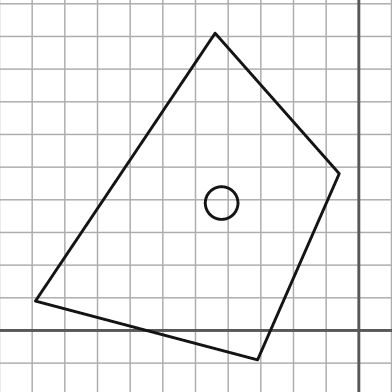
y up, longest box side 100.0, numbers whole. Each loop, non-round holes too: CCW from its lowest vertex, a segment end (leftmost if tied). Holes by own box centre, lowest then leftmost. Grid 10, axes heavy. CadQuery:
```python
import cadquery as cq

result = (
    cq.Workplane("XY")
    .moveTo(-31.0, -9.0)
    .lineTo(-6.0, 48.0)
    .lineTo(-44.0, 91.0)
    .lineTo(-99.0, 9.0)
    .close()
    .moveTo(-42.0, 39.0)
    .circle(5.0)
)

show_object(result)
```